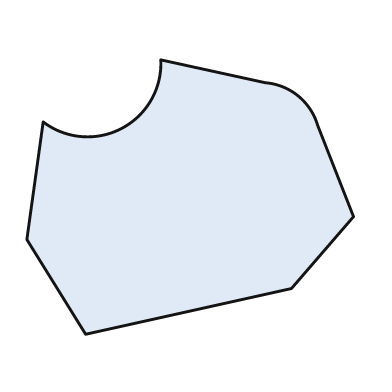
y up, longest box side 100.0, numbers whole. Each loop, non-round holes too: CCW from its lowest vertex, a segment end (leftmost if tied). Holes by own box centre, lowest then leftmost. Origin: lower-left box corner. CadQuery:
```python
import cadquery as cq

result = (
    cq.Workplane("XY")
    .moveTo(18.0, 0.0)
    .lineTo(81.0, 14.0)
    .lineTo(100.0, 36.0)
    .lineTo(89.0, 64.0)
    .threePointArc((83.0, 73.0), (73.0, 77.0))
    .lineTo(41.0, 84.0)
    .threePointArc((29.0, 63.0), (5.0, 65.0))
    .lineTo(0.0, 29.0)
    .close()
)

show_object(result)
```